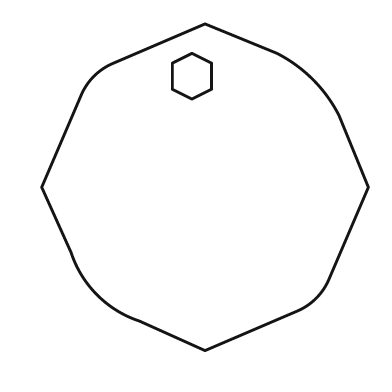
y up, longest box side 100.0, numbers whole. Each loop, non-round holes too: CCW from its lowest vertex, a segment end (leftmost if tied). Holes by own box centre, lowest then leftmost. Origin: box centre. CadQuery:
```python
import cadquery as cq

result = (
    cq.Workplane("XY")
    .moveTo(0.0, -50.0)
    .lineTo(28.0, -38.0)
    .threePointArc((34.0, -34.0), (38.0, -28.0))
    .lineTo(50.0, 0.0)
    .lineTo(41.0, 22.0)
    .threePointArc((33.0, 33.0), (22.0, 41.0))
    .lineTo(0.0, 50.0)
    .lineTo(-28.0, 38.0)
    .threePointArc((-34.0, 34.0), (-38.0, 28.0))
    .lineTo(-50.0, 0.0)
    .lineTo(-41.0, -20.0)
    .threePointArc((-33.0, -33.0), (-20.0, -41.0))
    .close()
    .moveTo(-4.0, 27.0)
    .lineTo(2.0, 30.0)
    .lineTo(2.0, 38.0)
    .lineTo(-4.0, 41.0)
    .lineTo(-10.0, 38.0)
    .lineTo(-10.0, 30.0)
    .close()
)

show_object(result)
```